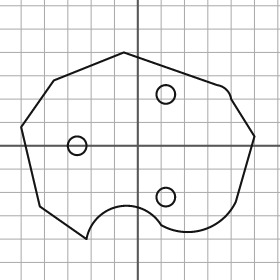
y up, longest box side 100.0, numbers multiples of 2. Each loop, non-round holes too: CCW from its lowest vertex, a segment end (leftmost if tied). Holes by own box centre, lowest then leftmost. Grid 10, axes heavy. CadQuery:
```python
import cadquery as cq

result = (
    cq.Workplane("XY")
    .moveTo(-22.0, -40.0)
    .threePointArc((-8.0, -26.0), (10.0, -34.0))
    .threePointArc((28.0, -36.0), (42.0, -24.0))
    .lineTo(50.0, 4.0)
    .lineTo(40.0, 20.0)
    .threePointArc((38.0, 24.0), (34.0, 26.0))
    .lineTo(-6.0, 40.0)
    .lineTo(-36.0, 28.0)
    .lineTo(-50.0, 8.0)
    .lineTo(-42.0, -26.0)
    .close()
    .moveTo(12.0, -22.0)
    .circle(4.0)
    .moveTo(-26.0, 0.0)
    .circle(4.0)
    .moveTo(12.0, 22.0)
    .circle(4.0)
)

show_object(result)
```